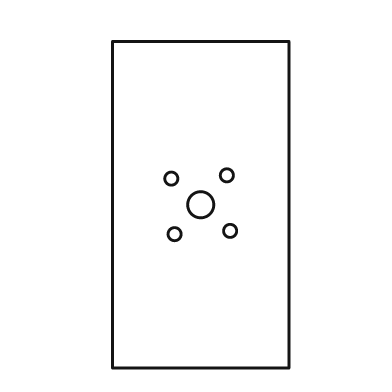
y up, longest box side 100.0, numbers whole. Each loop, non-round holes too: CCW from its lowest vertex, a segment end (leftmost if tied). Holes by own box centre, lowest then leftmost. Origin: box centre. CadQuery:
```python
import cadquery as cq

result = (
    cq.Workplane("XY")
    .moveTo(-27.0, -50.0)
    .lineTo(27.0, -50.0)
    .lineTo(27.0, 50.0)
    .lineTo(-27.0, 50.0)
    .close()
    .moveTo(-8.0, -9.0)
    .circle(2.0)
    .moveTo(9.0, -8.0)
    .circle(2.0)
    .moveTo(0.0, 0.0)
    .circle(4.0)
    .moveTo(-9.0, 8.0)
    .circle(2.0)
    .moveTo(8.0, 9.0)
    .circle(2.0)
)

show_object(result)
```